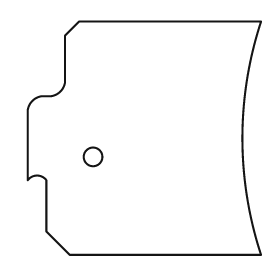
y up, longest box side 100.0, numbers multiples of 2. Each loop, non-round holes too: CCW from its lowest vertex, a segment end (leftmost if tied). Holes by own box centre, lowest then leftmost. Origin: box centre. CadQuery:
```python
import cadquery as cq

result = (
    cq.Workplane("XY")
    .moveTo(-32.0, -50.0)
    .lineTo(50.0, -50.0)
    .threePointArc((42.0, 0.0), (50.0, 50.0))
    .lineTo(-28.0, 50.0)
    .lineTo(-34.0, 44.0)
    .lineTo(-34.0, 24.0)
    .threePointArc((-36.0, 20.0), (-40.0, 18.0))
    .lineTo(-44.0, 18.0)
    .threePointArc((-48.0, 16.0), (-50.0, 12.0))
    .lineTo(-50.0, -18.0)
    .threePointArc((-46.0, -16.0), (-42.0, -18.0))
    .lineTo(-42.0, -40.0)
    .close()
    .moveTo(-22.0, -8.0)
    .circle(4.0)
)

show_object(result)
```